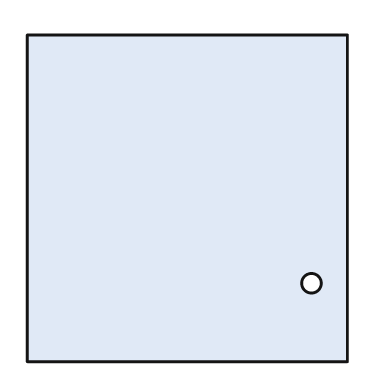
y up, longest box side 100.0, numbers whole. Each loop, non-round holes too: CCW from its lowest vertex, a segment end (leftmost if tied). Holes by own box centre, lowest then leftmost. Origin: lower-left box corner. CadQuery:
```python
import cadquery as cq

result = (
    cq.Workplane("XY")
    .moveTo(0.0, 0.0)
    .lineTo(98.0, 0.0)
    .lineTo(98.0, 100.0)
    .lineTo(0.0, 100.0)
    .close()
    .moveTo(87.0, 24.0)
    .circle(3.0)
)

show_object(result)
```